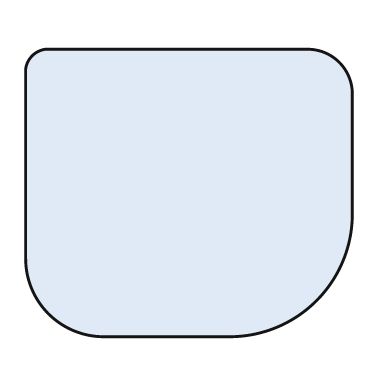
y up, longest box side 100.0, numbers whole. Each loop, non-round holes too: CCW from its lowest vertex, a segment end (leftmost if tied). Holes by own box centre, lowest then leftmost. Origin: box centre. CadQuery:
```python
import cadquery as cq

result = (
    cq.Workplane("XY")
    .moveTo(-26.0, -44.0)
    .lineTo(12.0, -44.0)
    .threePointArc((39.0, -33.0), (50.0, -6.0))
    .lineTo(50.0, 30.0)
    .threePointArc((46.0, 40.0), (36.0, 44.0))
    .lineTo(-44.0, 44.0)
    .threePointArc((-48.0, 42.0), (-50.0, 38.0))
    .lineTo(-50.0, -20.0)
    .threePointArc((-43.0, -37.0), (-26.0, -44.0))
    .close()
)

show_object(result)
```